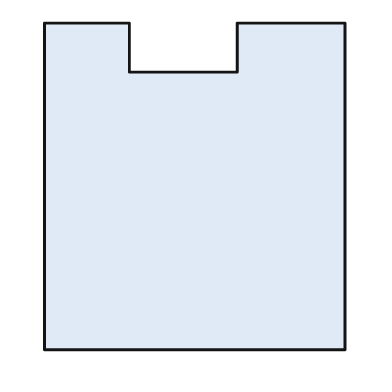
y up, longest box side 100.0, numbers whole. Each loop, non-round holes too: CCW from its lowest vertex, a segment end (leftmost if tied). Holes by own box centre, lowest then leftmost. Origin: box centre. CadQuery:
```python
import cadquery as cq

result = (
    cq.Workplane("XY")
    .moveTo(-46.0, -50.0)
    .lineTo(46.0, -50.0)
    .lineTo(46.0, 50.0)
    .lineTo(13.0, 50.0)
    .lineTo(13.0, 35.0)
    .lineTo(-20.0, 35.0)
    .lineTo(-20.0, 50.0)
    .lineTo(-46.0, 50.0)
    .close()
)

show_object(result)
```